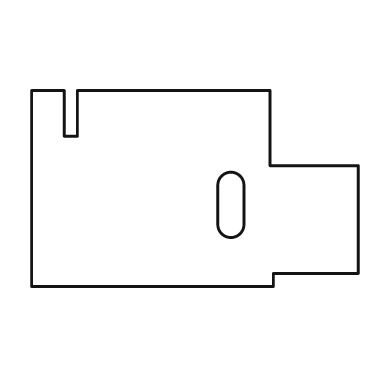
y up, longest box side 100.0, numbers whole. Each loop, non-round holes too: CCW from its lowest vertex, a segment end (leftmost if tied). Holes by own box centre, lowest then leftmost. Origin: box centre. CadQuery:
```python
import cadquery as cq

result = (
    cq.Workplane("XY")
    .moveTo(-50.0, -30.0)
    .lineTo(24.0, -30.0)
    .lineTo(24.0, -26.0)
    .lineTo(50.0, -26.0)
    .lineTo(50.0, 7.0)
    .lineTo(23.0, 7.0)
    .lineTo(23.0, 30.0)
    .lineTo(-36.0, 30.0)
    .lineTo(-36.0, 16.0)
    .lineTo(-40.0, 16.0)
    .lineTo(-40.0, 30.0)
    .lineTo(-50.0, 30.0)
    .close()
    .moveTo(7.0, -11.0)
    .threePointArc((11.0, -15.0), (15.0, -11.0))
    .lineTo(15.0, 1.0)
    .threePointArc((11.0, 5.0), (7.0, 1.0))
    .close()
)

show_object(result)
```